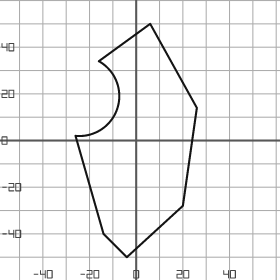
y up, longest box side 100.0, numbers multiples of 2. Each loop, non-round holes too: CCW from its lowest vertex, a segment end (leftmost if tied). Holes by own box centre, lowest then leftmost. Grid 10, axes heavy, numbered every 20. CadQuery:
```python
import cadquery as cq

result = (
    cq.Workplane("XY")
    .moveTo(-4.0, -50.0)
    .lineTo(20.0, -28.0)
    .lineTo(26.0, 14.0)
    .lineTo(6.0, 50.0)
    .lineTo(-16.0, 34.0)
    .threePointArc((-8.0, 14.0), (-26.0, 2.0))
    .lineTo(-14.0, -40.0)
    .close()
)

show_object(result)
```